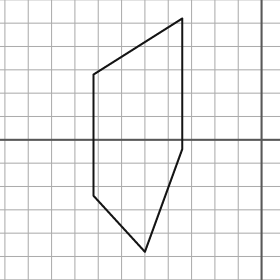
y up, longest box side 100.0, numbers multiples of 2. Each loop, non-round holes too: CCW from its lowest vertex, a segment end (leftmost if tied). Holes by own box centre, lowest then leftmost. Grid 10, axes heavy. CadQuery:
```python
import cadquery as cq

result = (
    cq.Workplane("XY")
    .moveTo(-50.0, -48.0)
    .lineTo(-34.0, -4.0)
    .lineTo(-34.0, 52.0)
    .lineTo(-72.0, 28.0)
    .lineTo(-72.0, -24.0)
    .close()
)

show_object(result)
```